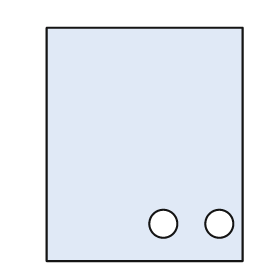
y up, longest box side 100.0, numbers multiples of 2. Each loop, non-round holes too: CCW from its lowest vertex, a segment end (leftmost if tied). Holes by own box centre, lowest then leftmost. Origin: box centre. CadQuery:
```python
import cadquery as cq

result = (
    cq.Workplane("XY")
    .moveTo(-42.0, -50.0)
    .lineTo(42.0, -50.0)
    .lineTo(42.0, 50.0)
    .lineTo(-42.0, 50.0)
    .close()
    .moveTo(8.0, -34.0)
    .circle(6.0)
    .moveTo(32.0, -34.0)
    .circle(6.0)
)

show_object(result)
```